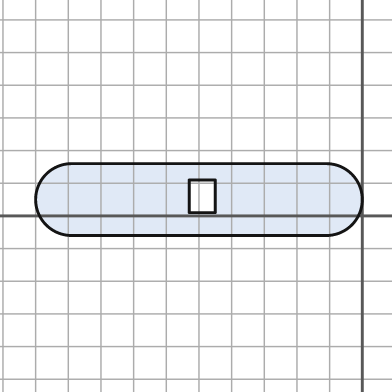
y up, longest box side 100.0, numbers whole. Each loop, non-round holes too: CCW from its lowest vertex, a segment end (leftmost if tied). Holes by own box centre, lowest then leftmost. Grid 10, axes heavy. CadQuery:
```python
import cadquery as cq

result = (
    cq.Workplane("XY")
    .moveTo(-89.0, -6.0)
    .lineTo(-11.0, -6.0)
    .threePointArc((0.0, 5.0), (-11.0, 16.0))
    .lineTo(-89.0, 16.0)
    .threePointArc((-100.0, 5.0), (-89.0, -6.0))
    .close()
    .moveTo(-53.0, 1.0)
    .lineTo(-45.0, 1.0)
    .lineTo(-45.0, 11.0)
    .lineTo(-53.0, 11.0)
    .close()
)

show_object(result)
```